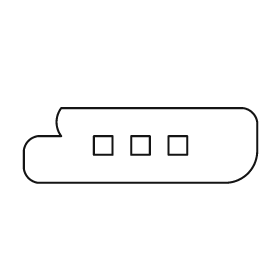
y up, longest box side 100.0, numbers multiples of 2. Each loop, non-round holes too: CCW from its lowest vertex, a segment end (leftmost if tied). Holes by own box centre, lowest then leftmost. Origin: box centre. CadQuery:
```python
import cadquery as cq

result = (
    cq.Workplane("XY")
    .moveTo(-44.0, -16.0)
    .lineTo(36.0, -16.0)
    .threePointArc((46.0, -12.0), (50.0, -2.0))
    .lineTo(50.0, 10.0)
    .threePointArc((48.0, 14.0), (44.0, 16.0))
    .lineTo(-34.0, 16.0)
    .threePointArc((-36.0, 10.0), (-34.0, 4.0))
    .lineTo(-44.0, 4.0)
    .threePointArc((-48.0, 2.0), (-50.0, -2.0))
    .lineTo(-50.0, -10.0)
    .threePointArc((-48.0, -14.0), (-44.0, -16.0))
    .close()
    .moveTo(-20.0, -4.0)
    .lineTo(-12.0, -4.0)
    .lineTo(-12.0, 4.0)
    .lineTo(-20.0, 4.0)
    .close()
    .moveTo(-4.0, -4.0)
    .lineTo(4.0, -4.0)
    .lineTo(4.0, 4.0)
    .lineTo(-4.0, 4.0)
    .close()
    .moveTo(12.0, -4.0)
    .lineTo(20.0, -4.0)
    .lineTo(20.0, 4.0)
    .lineTo(12.0, 4.0)
    .close()
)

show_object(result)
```